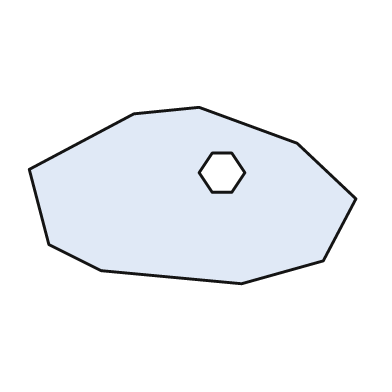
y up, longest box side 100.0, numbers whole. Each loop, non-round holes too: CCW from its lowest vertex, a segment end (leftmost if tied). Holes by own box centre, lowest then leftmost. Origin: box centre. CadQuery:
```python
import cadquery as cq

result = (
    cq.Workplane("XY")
    .moveTo(15.0, -27.0)
    .lineTo(40.0, -20.0)
    .lineTo(50.0, -1.0)
    .lineTo(32.0, 16.0)
    .lineTo(2.0, 27.0)
    .lineTo(-18.0, 25.0)
    .lineTo(-50.0, 8.0)
    .lineTo(-44.0, -15.0)
    .lineTo(-28.0, -23.0)
    .close()
    .moveTo(6.0, 1.0)
    .lineTo(12.0, 1.0)
    .lineTo(16.0, 7.0)
    .lineTo(12.0, 13.0)
    .lineTo(6.0, 13.0)
    .lineTo(2.0, 7.0)
    .close()
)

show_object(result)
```